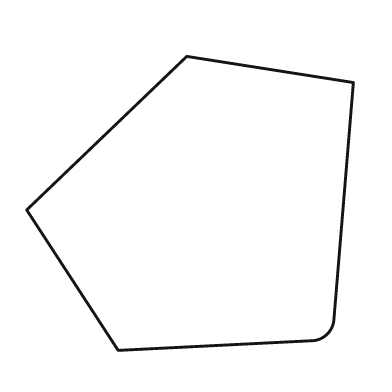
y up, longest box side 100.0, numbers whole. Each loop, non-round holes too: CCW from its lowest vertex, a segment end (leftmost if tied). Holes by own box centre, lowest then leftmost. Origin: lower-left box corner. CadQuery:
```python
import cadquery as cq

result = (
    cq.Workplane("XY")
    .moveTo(28.0, 0.0)
    .lineTo(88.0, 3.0)
    .threePointArc((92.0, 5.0), (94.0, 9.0))
    .lineTo(100.0, 82.0)
    .lineTo(49.0, 90.0)
    .lineTo(0.0, 43.0)
    .close()
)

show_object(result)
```